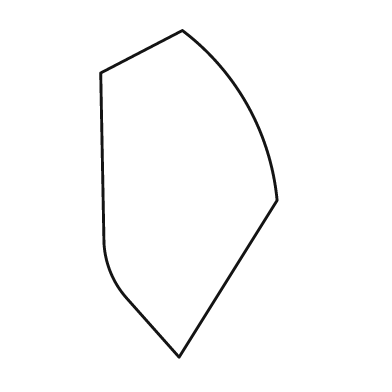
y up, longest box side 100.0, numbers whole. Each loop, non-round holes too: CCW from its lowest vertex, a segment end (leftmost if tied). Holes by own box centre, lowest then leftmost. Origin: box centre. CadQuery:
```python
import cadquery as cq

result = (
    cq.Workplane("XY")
    .moveTo(-3.0, -50.0)
    .lineTo(27.0, -2.0)
    .threePointArc((18.0, 27.0), (-2.0, 50.0))
    .lineTo(-27.0, 37.0)
    .lineTo(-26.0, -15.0)
    .threePointArc((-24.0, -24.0), (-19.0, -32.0))
    .close()
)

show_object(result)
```